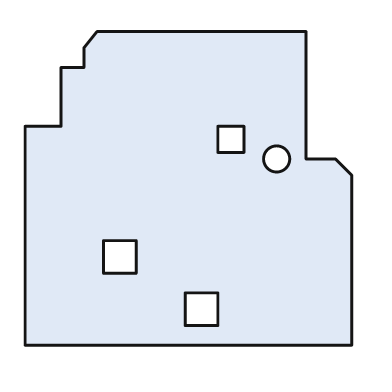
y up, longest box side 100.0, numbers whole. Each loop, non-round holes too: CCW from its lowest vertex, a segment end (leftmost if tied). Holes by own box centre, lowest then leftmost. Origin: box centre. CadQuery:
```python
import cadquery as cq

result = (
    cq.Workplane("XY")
    .moveTo(-50.0, -48.0)
    .lineTo(50.0, -48.0)
    .lineTo(50.0, 4.0)
    .lineTo(45.0, 9.0)
    .lineTo(36.0, 9.0)
    .lineTo(36.0, 48.0)
    .lineTo(-28.0, 48.0)
    .lineTo(-32.0, 43.0)
    .lineTo(-32.0, 37.0)
    .lineTo(-39.0, 37.0)
    .lineTo(-39.0, 19.0)
    .lineTo(-50.0, 19.0)
    .close()
    .moveTo(-1.0, -42.0)
    .lineTo(9.0, -42.0)
    .lineTo(9.0, -32.0)
    .lineTo(-1.0, -32.0)
    .close()
    .moveTo(-26.0, -26.0)
    .lineTo(-16.0, -26.0)
    .lineTo(-16.0, -16.0)
    .lineTo(-26.0, -16.0)
    .close()
    .moveTo(27.0, 9.0)
    .circle(4.0)
    .moveTo(9.0, 11.0)
    .lineTo(17.0, 11.0)
    .lineTo(17.0, 19.0)
    .lineTo(9.0, 19.0)
    .close()
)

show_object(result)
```